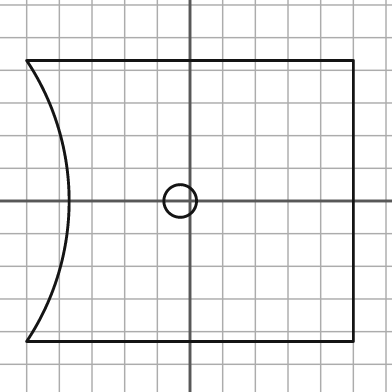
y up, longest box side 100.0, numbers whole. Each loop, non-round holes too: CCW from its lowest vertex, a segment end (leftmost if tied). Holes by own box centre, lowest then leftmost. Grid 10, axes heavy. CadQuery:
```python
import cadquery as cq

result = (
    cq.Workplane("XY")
    .moveTo(-50.0, -43.0)
    .lineTo(50.0, -43.0)
    .lineTo(50.0, 43.0)
    .lineTo(-50.0, 43.0)
    .threePointArc((-37.0, 0.0), (-50.0, -43.0))
    .close()
    .moveTo(-3.0, 0.0)
    .circle(5.0)
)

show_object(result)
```